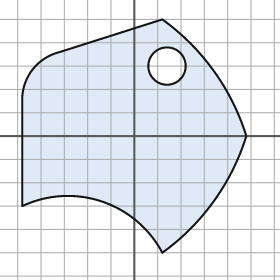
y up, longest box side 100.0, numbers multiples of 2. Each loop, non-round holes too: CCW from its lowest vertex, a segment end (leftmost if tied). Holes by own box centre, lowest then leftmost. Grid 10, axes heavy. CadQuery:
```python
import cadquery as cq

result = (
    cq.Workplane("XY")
    .moveTo(12.0, -50.0)
    .threePointArc((34.0, -28.0), (48.0, 0.0))
    .threePointArc((34.0, 28.0), (12.0, 50.0))
    .lineTo(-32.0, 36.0)
    .threePointArc((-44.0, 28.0), (-48.0, 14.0))
    .lineTo(-48.0, -30.0)
    .threePointArc((-14.0, -28.0), (12.0, -50.0))
    .close()
    .moveTo(14.0, 30.0)
    .circle(8.0)
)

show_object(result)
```